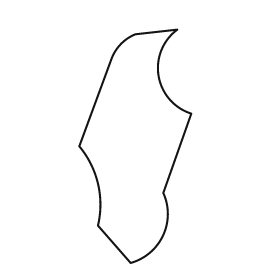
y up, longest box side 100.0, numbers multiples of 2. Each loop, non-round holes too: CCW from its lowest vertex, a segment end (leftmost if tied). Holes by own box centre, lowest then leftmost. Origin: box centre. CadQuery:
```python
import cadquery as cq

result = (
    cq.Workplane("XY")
    .moveTo(-2.0, -50.0)
    .threePointArc((12.0, -38.0), (12.0, -20.0))
    .lineTo(24.0, 14.0)
    .threePointArc((10.0, 30.0), (18.0, 50.0))
    .lineTo(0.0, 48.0)
    .threePointArc((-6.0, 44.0), (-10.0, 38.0))
    .lineTo(-24.0, 0.0)
    .threePointArc((-16.0, -16.0), (-16.0, -34.0))
    .close()
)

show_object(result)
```